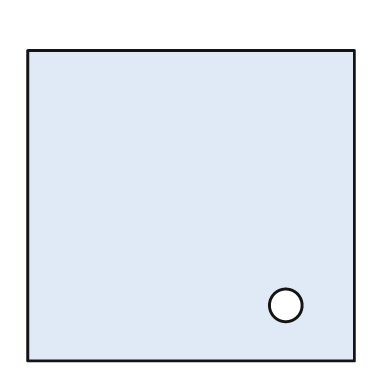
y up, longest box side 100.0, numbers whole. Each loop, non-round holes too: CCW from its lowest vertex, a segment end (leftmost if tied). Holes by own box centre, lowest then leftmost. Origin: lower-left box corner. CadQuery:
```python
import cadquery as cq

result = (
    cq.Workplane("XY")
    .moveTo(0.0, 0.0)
    .lineTo(100.0, 0.0)
    .lineTo(100.0, 95.0)
    .lineTo(0.0, 95.0)
    .close()
    .moveTo(79.0, 17.0)
    .circle(5.0)
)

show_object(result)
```